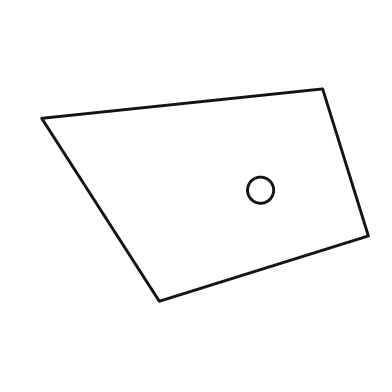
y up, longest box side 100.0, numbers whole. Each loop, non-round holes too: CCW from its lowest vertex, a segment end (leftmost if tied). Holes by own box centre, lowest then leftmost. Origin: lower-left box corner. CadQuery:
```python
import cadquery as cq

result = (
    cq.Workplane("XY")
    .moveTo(36.0, 0.0)
    .lineTo(100.0, 20.0)
    .lineTo(86.0, 65.0)
    .lineTo(0.0, 56.0)
    .close()
    .moveTo(67.0, 34.0)
    .circle(4.0)
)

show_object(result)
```